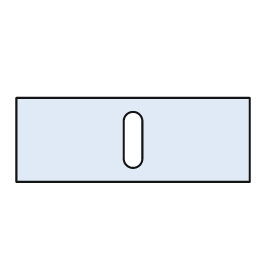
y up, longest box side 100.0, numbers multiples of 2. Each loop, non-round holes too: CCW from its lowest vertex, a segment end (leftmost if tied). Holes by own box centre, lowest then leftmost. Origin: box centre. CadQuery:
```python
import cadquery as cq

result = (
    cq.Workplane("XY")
    .moveTo(-50.0, -18.0)
    .lineTo(50.0, -18.0)
    .lineTo(50.0, 18.0)
    .lineTo(-50.0, 18.0)
    .close()
    .moveTo(-4.0, -8.0)
    .threePointArc((0.0, -12.0), (4.0, -8.0))
    .lineTo(4.0, 8.0)
    .threePointArc((0.0, 12.0), (-4.0, 8.0))
    .close()
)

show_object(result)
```